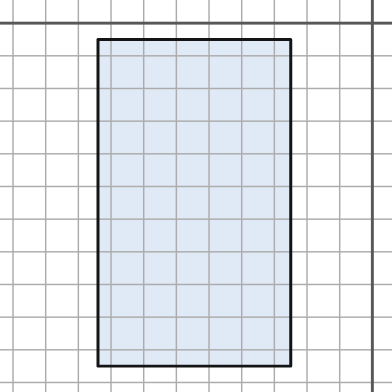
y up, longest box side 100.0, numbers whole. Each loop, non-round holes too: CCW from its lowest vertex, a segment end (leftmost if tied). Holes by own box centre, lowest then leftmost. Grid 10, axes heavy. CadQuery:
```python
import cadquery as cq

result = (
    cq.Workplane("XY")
    .moveTo(-84.0, -105.0)
    .lineTo(-25.0, -105.0)
    .lineTo(-25.0, -5.0)
    .lineTo(-84.0, -5.0)
    .close()
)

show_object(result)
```